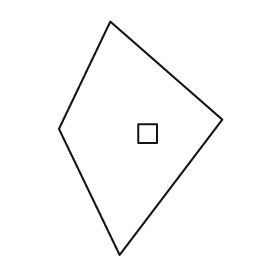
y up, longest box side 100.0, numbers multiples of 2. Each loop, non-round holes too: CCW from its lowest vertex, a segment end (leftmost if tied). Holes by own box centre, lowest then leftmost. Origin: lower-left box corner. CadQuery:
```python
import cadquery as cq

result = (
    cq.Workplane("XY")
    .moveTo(26.0, 0.0)
    .lineTo(70.0, 58.0)
    .lineTo(22.0, 100.0)
    .lineTo(0.0, 54.0)
    .close()
    .moveTo(34.0, 48.0)
    .lineTo(42.0, 48.0)
    .lineTo(42.0, 56.0)
    .lineTo(34.0, 56.0)
    .close()
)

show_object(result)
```